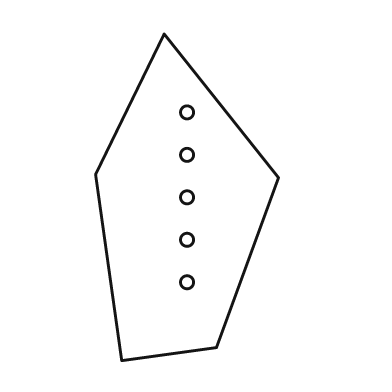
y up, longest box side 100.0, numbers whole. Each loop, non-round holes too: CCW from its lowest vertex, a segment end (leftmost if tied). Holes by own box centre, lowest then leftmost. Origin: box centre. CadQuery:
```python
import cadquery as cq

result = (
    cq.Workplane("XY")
    .moveTo(-20.0, -50.0)
    .lineTo(9.0, -46.0)
    .lineTo(28.0, 6.0)
    .lineTo(-7.0, 50.0)
    .lineTo(-28.0, 7.0)
    .close()
    .moveTo(0.0, -26.0)
    .circle(2.0)
    .moveTo(0.0, -13.0)
    .circle(2.0)
    .moveTo(0.0, 0.0)
    .circle(2.0)
    .moveTo(0.0, 13.0)
    .circle(2.0)
    .moveTo(0.0, 26.0)
    .circle(2.0)
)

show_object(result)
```